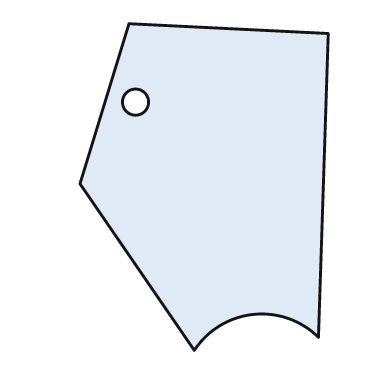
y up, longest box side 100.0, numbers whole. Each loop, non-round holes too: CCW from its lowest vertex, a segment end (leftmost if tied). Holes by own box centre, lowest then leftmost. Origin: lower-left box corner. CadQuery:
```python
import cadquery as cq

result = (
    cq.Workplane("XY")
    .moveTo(35.0, 0.0)
    .threePointArc((53.0, 11.0), (73.0, 4.0))
    .lineTo(76.0, 97.0)
    .lineTo(15.0, 100.0)
    .lineTo(0.0, 51.0)
    .close()
    .moveTo(17.0, 76.0)
    .circle(4.0)
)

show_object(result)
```